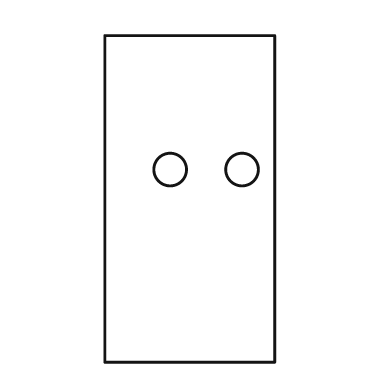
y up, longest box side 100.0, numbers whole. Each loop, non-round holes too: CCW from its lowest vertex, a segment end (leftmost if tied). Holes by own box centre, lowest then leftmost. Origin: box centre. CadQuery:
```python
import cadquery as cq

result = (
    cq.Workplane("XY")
    .moveTo(-26.0, -50.0)
    .lineTo(26.0, -50.0)
    .lineTo(26.0, 50.0)
    .lineTo(-26.0, 50.0)
    .close()
    .moveTo(-6.0, 9.0)
    .circle(5.0)
    .moveTo(16.0, 9.0)
    .circle(5.0)
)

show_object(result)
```